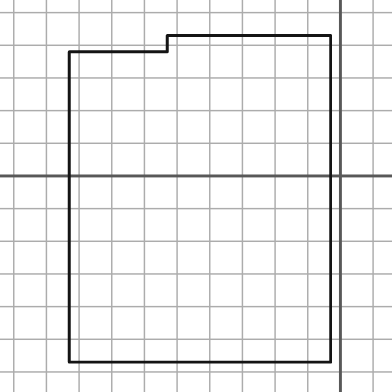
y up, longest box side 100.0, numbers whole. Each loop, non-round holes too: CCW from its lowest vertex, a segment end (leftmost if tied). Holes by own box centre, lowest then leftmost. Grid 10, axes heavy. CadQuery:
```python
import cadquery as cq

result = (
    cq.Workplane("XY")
    .moveTo(-83.0, -57.0)
    .lineTo(-3.0, -57.0)
    .lineTo(-3.0, 43.0)
    .lineTo(-53.0, 43.0)
    .lineTo(-53.0, 38.0)
    .lineTo(-83.0, 38.0)
    .close()
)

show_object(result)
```